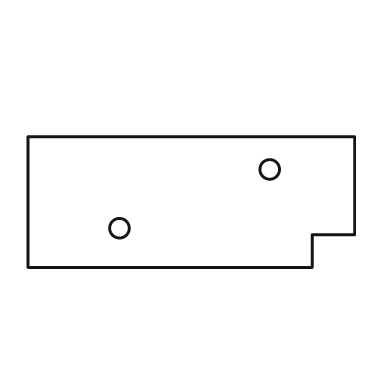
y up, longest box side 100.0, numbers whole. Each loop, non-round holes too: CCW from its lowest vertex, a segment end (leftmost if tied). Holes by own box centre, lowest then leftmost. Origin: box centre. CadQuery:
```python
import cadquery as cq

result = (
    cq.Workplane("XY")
    .moveTo(-50.0, -20.0)
    .lineTo(37.0, -20.0)
    .lineTo(37.0, -10.0)
    .lineTo(50.0, -10.0)
    .lineTo(50.0, 20.0)
    .lineTo(-50.0, 20.0)
    .close()
    .moveTo(-22.0, -8.0)
    .circle(3.0)
    .moveTo(24.0, 10.0)
    .circle(3.0)
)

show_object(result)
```